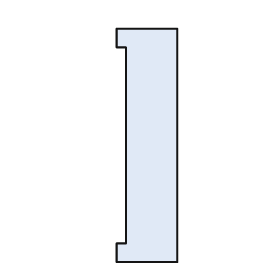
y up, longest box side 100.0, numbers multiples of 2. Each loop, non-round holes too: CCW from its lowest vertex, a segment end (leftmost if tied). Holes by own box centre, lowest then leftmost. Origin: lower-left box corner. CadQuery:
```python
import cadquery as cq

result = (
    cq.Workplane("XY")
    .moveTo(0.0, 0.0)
    .lineTo(26.0, 0.0)
    .lineTo(26.0, 100.0)
    .lineTo(0.0, 100.0)
    .lineTo(0.0, 92.0)
    .lineTo(4.0, 92.0)
    .lineTo(4.0, 8.0)
    .lineTo(0.0, 8.0)
    .close()
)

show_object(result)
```